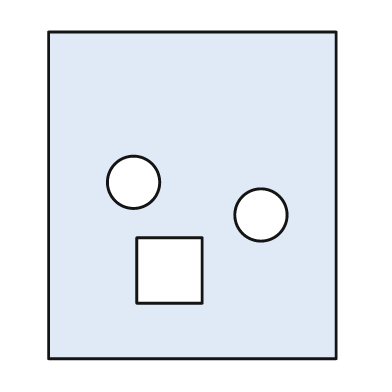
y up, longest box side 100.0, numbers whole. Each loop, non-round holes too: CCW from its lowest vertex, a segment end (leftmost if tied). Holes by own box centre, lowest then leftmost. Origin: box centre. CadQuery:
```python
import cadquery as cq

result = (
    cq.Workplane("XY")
    .moveTo(-44.0, -50.0)
    .lineTo(44.0, -50.0)
    .lineTo(44.0, 50.0)
    .lineTo(-44.0, 50.0)
    .close()
    .moveTo(-17.0, -33.0)
    .lineTo(3.0, -33.0)
    .lineTo(3.0, -13.0)
    .lineTo(-17.0, -13.0)
    .close()
    .moveTo(21.0, -6.0)
    .circle(8.0)
    .moveTo(-18.0, 4.0)
    .circle(8.0)
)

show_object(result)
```